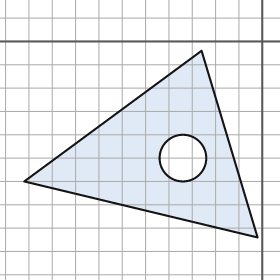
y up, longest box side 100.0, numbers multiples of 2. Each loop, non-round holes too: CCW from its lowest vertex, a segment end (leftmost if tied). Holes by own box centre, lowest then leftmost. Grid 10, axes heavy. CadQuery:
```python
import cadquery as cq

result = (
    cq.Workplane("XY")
    .moveTo(-2.0, -84.0)
    .lineTo(-26.0, -4.0)
    .lineTo(-102.0, -60.0)
    .close()
    .moveTo(-34.0, -50.0)
    .circle(10.0)
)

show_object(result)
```